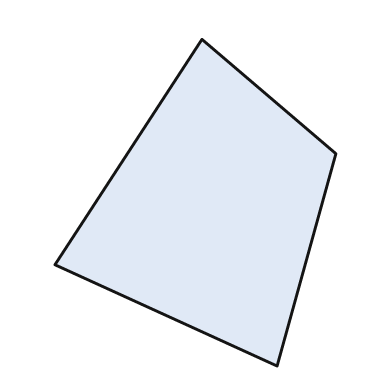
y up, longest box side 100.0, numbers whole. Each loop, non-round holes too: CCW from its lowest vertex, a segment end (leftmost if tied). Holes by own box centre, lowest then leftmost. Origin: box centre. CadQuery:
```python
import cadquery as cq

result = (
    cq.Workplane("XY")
    .moveTo(25.0, -50.0)
    .lineTo(43.0, 15.0)
    .lineTo(2.0, 50.0)
    .lineTo(-43.0, -19.0)
    .close()
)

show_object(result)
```